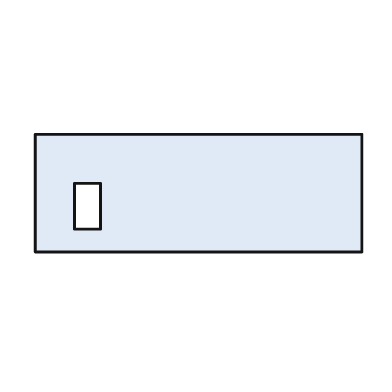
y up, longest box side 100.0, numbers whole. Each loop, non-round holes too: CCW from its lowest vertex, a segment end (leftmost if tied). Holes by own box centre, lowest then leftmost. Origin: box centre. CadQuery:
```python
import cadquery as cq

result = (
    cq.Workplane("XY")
    .moveTo(-50.0, -18.0)
    .lineTo(50.0, -18.0)
    .lineTo(50.0, 18.0)
    .lineTo(-50.0, 18.0)
    .close()
    .moveTo(-38.0, -11.0)
    .lineTo(-30.0, -11.0)
    .lineTo(-30.0, 3.0)
    .lineTo(-38.0, 3.0)
    .close()
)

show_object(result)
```